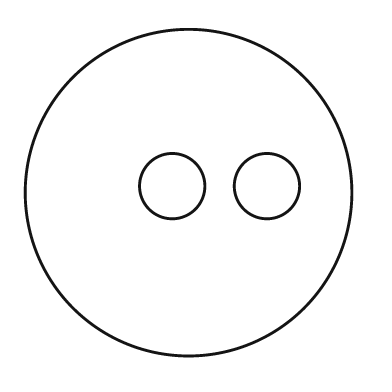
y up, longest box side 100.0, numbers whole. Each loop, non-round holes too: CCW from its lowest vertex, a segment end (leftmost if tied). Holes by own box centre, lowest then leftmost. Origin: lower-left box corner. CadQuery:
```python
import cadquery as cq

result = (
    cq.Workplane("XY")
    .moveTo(50.0, 50.0)
    .circle(50.0)
    .moveTo(45.0, 52.0)
    .circle(10.0)
    .moveTo(74.0, 52.0)
    .circle(10.0)
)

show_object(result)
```